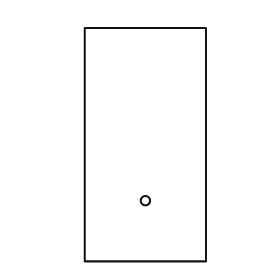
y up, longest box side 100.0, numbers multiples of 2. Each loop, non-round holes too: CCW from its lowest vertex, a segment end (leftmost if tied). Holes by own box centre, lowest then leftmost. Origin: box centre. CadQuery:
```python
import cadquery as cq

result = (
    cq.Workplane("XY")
    .moveTo(-26.0, -50.0)
    .lineTo(26.0, -50.0)
    .lineTo(26.0, 50.0)
    .lineTo(-26.0, 50.0)
    .close()
    .moveTo(0.0, -24.0)
    .circle(2.0)
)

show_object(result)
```